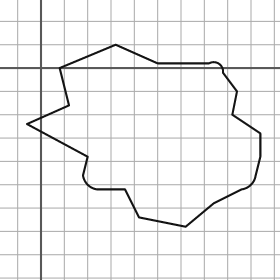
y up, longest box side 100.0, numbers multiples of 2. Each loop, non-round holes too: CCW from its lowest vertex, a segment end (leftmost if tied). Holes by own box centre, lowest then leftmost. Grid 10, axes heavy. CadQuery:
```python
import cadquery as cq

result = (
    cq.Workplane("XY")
    .moveTo(62.0, -68.0)
    .lineTo(74.0, -58.0)
    .lineTo(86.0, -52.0)
    .threePointArc((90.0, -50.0), (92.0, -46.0))
    .lineTo(94.0, -38.0)
    .lineTo(94.0, -28.0)
    .lineTo(82.0, -20.0)
    .lineTo(84.0, -10.0)
    .lineTo(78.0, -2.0)
    .threePointArc((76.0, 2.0), (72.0, 2.0))
    .lineTo(50.0, 2.0)
    .lineTo(32.0, 10.0)
    .lineTo(8.0, 0.0)
    .lineTo(12.0, -16.0)
    .lineTo(-6.0, -24.0)
    .lineTo(20.0, -38.0)
    .lineTo(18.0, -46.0)
    .threePointArc((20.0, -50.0), (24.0, -52.0))
    .lineTo(36.0, -52.0)
    .lineTo(42.0, -64.0)
    .close()
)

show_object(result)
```